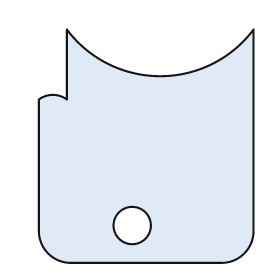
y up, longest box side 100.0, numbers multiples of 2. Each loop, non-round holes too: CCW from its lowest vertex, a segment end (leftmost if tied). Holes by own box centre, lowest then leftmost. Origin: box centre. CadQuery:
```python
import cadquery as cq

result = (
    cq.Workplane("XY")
    .moveTo(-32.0, -50.0)
    .lineTo(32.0, -50.0)
    .threePointArc((42.0, -46.0), (46.0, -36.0))
    .lineTo(46.0, 50.0)
    .threePointArc((6.0, 30.0), (-34.0, 50.0))
    .lineTo(-34.0, 20.0)
    .threePointArc((-40.0, 22.0), (-46.0, 20.0))
    .lineTo(-46.0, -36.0)
    .threePointArc((-42.0, -46.0), (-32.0, -50.0))
    .close()
    .moveTo(-6.0, -34.0)
    .circle(8.0)
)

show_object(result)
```